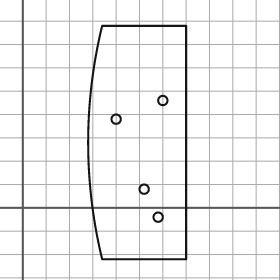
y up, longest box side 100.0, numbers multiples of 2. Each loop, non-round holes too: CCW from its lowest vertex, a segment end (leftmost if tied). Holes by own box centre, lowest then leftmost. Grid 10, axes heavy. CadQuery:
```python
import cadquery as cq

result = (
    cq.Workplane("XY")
    .moveTo(34.0, -22.0)
    .lineTo(70.0, -22.0)
    .lineTo(70.0, 78.0)
    .lineTo(34.0, 78.0)
    .threePointArc((28.0, 28.0), (34.0, -22.0))
    .close()
    .moveTo(58.0, -4.0)
    .circle(2.0)
    .moveTo(52.0, 8.0)
    .circle(2.0)
    .moveTo(40.0, 38.0)
    .circle(2.0)
    .moveTo(60.0, 46.0)
    .circle(2.0)
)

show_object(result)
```